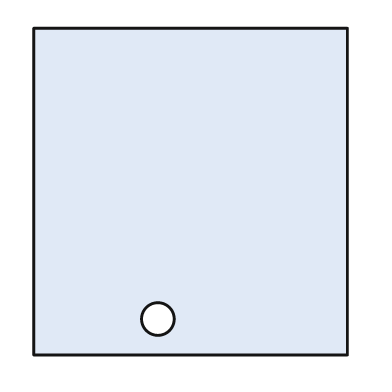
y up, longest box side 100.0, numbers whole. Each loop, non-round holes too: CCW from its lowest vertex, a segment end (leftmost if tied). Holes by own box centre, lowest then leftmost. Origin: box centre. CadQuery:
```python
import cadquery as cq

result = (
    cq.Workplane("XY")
    .moveTo(-48.0, -50.0)
    .lineTo(48.0, -50.0)
    .lineTo(48.0, 50.0)
    .lineTo(-48.0, 50.0)
    .close()
    .moveTo(-10.0, -39.0)
    .circle(5.0)
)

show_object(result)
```